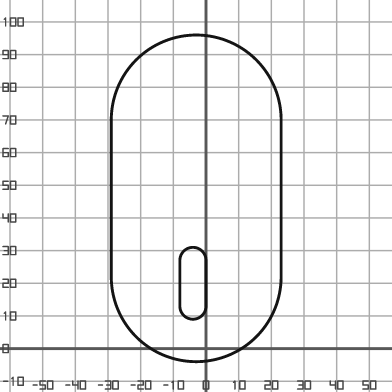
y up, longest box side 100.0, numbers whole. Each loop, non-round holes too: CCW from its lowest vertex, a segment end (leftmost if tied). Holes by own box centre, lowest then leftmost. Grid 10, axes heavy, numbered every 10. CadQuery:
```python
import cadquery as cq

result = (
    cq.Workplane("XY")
    .moveTo(-29.0, 22.0)
    .threePointArc((-3.0, -4.0), (23.0, 22.0))
    .lineTo(23.0, 70.0)
    .threePointArc((-3.0, 96.0), (-29.0, 70.0))
    .close()
    .moveTo(-8.0, 13.0)
    .threePointArc((-4.0, 9.0), (0.0, 13.0))
    .lineTo(0.0, 27.0)
    .threePointArc((-4.0, 31.0), (-8.0, 27.0))
    .close()
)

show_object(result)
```